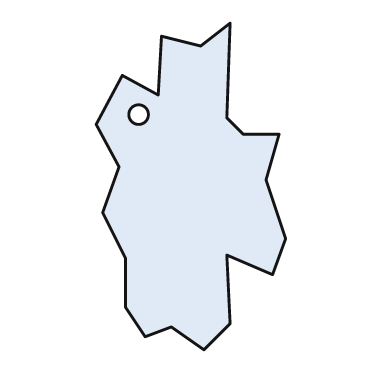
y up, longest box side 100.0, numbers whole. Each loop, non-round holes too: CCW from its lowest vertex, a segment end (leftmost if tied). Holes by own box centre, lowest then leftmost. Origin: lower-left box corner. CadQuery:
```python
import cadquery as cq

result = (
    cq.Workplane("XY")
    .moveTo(33.0, 0.0)
    .lineTo(41.0, 8.0)
    .lineTo(40.0, 29.0)
    .lineTo(54.0, 23.0)
    .lineTo(58.0, 34.0)
    .lineTo(52.0, 52.0)
    .lineTo(56.0, 66.0)
    .lineTo(45.0, 66.0)
    .lineTo(40.0, 71.0)
    .lineTo(41.0, 100.0)
    .lineTo(32.0, 93.0)
    .lineTo(20.0, 96.0)
    .lineTo(19.0, 78.0)
    .lineTo(8.0, 84.0)
    .lineTo(0.0, 69.0)
    .lineTo(7.0, 56.0)
    .lineTo(2.0, 42.0)
    .lineTo(9.0, 28.0)
    .lineTo(9.0, 13.0)
    .lineTo(15.0, 4.0)
    .lineTo(23.0, 7.0)
    .close()
    .moveTo(13.0, 72.0)
    .circle(3.0)
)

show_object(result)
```